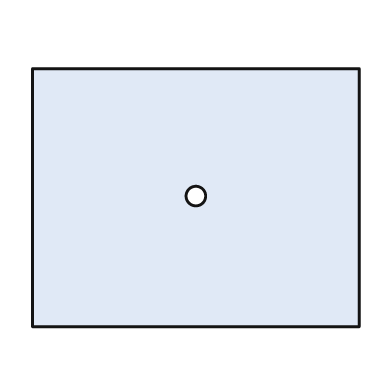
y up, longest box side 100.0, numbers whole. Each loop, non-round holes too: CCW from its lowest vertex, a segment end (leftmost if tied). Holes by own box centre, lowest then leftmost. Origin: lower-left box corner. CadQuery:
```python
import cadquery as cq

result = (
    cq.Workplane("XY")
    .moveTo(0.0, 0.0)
    .lineTo(100.0, 0.0)
    .lineTo(100.0, 79.0)
    .lineTo(0.0, 79.0)
    .close()
    .moveTo(50.0, 40.0)
    .circle(3.0)
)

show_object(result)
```